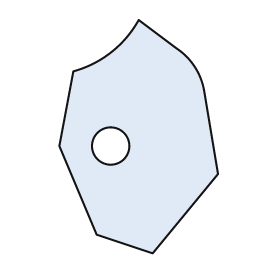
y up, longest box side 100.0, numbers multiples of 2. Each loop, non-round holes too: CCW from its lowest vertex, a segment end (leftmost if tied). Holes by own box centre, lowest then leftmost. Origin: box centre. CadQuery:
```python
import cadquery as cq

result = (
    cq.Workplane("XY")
    .moveTo(6.0, -50.0)
    .lineTo(34.0, -16.0)
    .lineTo(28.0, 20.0)
    .threePointArc((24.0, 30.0), (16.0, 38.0))
    .lineTo(0.0, 50.0)
    .threePointArc((-12.0, 36.0), (-28.0, 28.0))
    .lineTo(-34.0, -4.0)
    .lineTo(-18.0, -42.0)
    .close()
    .moveTo(-12.0, -4.0)
    .circle(8.0)
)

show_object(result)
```